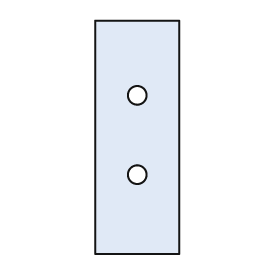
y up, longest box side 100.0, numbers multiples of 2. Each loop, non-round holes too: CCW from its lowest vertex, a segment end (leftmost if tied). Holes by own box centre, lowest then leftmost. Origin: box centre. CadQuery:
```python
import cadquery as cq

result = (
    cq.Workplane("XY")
    .moveTo(-18.0, -50.0)
    .lineTo(18.0, -50.0)
    .lineTo(18.0, 50.0)
    .lineTo(-18.0, 50.0)
    .close()
    .moveTo(0.0, -16.0)
    .circle(4.0)
    .moveTo(0.0, 18.0)
    .circle(4.0)
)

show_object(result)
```